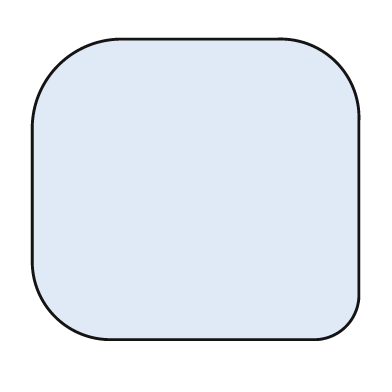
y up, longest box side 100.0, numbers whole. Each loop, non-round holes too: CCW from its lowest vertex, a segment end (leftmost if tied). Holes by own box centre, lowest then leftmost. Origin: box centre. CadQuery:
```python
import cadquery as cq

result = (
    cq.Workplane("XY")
    .moveTo(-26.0, -46.0)
    .lineTo(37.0, -46.0)
    .threePointArc((46.0, -42.0), (50.0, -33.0))
    .lineTo(50.0, 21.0)
    .threePointArc((43.0, 39.0), (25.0, 46.0))
    .lineTo(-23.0, 46.0)
    .threePointArc((-42.0, 38.0), (-50.0, 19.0))
    .lineTo(-50.0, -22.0)
    .threePointArc((-43.0, -39.0), (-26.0, -46.0))
    .close()
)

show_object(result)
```